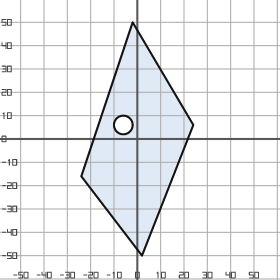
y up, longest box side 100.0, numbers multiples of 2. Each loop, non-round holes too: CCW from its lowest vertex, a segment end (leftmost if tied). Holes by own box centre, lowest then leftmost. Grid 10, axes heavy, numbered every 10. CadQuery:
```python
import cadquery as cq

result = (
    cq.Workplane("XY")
    .moveTo(2.0, -50.0)
    .lineTo(24.0, 6.0)
    .lineTo(-2.0, 50.0)
    .lineTo(-24.0, -16.0)
    .close()
    .moveTo(-6.0, 6.0)
    .circle(4.0)
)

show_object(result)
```